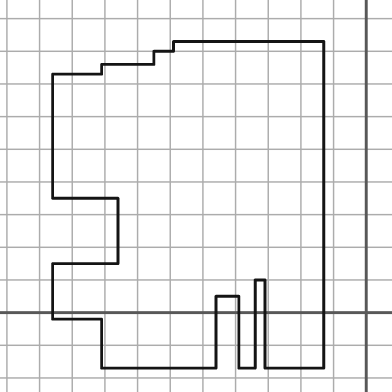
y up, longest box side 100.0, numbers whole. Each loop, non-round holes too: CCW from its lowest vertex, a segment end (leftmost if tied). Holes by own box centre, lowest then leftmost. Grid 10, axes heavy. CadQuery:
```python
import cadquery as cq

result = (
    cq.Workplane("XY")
    .moveTo(-81.0, -17.0)
    .lineTo(-46.0, -17.0)
    .lineTo(-46.0, 5.0)
    .lineTo(-39.0, 5.0)
    .lineTo(-39.0, -17.0)
    .lineTo(-34.0, -17.0)
    .lineTo(-34.0, 10.0)
    .lineTo(-31.0, 10.0)
    .lineTo(-31.0, -17.0)
    .lineTo(-13.0, -17.0)
    .lineTo(-13.0, 83.0)
    .lineTo(-59.0, 83.0)
    .lineTo(-59.0, 80.0)
    .lineTo(-65.0, 80.0)
    .lineTo(-65.0, 76.0)
    .lineTo(-81.0, 76.0)
    .lineTo(-81.0, 73.0)
    .lineTo(-96.0, 73.0)
    .lineTo(-96.0, 35.0)
    .lineTo(-76.0, 35.0)
    .lineTo(-76.0, 15.0)
    .lineTo(-96.0, 15.0)
    .lineTo(-96.0, -2.0)
    .lineTo(-81.0, -2.0)
    .close()
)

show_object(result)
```